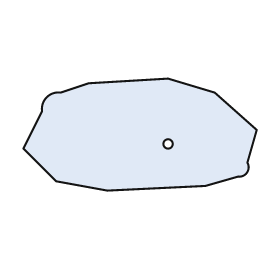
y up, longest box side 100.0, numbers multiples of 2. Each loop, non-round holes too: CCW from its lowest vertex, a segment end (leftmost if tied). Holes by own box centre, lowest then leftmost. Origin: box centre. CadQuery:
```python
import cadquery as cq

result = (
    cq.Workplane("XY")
    .moveTo(-14.0, -24.0)
    .lineTo(28.0, -22.0)
    .lineTo(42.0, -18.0)
    .threePointArc((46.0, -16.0), (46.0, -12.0))
    .lineTo(50.0, 2.0)
    .lineTo(32.0, 18.0)
    .lineTo(12.0, 24.0)
    .lineTo(-22.0, 22.0)
    .lineTo(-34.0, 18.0)
    .threePointArc((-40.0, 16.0), (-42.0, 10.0))
    .lineTo(-50.0, -6.0)
    .lineTo(-36.0, -20.0)
    .close()
    .moveTo(12.0, -4.0)
    .circle(2.0)
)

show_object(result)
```